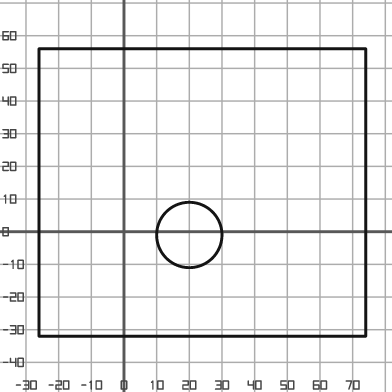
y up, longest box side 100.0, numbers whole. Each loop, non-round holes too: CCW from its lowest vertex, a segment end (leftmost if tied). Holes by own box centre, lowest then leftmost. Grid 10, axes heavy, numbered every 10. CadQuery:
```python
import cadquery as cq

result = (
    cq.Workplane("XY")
    .moveTo(-26.0, -32.0)
    .lineTo(74.0, -32.0)
    .lineTo(74.0, 56.0)
    .lineTo(-26.0, 56.0)
    .close()
    .moveTo(20.0, -1.0)
    .circle(10.0)
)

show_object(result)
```